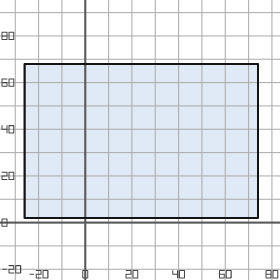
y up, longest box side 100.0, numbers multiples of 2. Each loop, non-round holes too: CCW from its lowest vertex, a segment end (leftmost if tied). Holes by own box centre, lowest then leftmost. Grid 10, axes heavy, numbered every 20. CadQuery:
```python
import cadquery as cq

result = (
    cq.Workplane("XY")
    .moveTo(-26.0, 2.0)
    .lineTo(74.0, 2.0)
    .lineTo(74.0, 68.0)
    .lineTo(-26.0, 68.0)
    .close()
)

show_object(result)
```